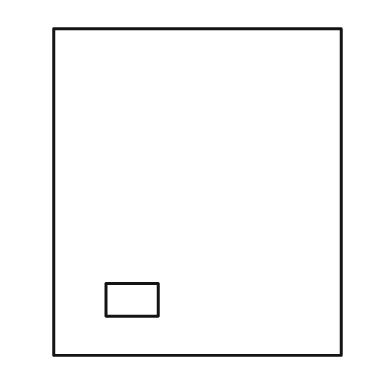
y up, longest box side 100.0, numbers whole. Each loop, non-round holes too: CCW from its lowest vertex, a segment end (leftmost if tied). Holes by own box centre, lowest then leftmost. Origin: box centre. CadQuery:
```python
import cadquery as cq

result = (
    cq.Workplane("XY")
    .moveTo(-44.0, -50.0)
    .lineTo(44.0, -50.0)
    .lineTo(44.0, 50.0)
    .lineTo(-44.0, 50.0)
    .close()
    .moveTo(-28.0, -38.0)
    .lineTo(-12.0, -38.0)
    .lineTo(-12.0, -28.0)
    .lineTo(-28.0, -28.0)
    .close()
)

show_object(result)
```